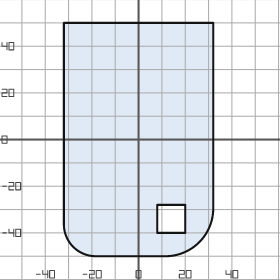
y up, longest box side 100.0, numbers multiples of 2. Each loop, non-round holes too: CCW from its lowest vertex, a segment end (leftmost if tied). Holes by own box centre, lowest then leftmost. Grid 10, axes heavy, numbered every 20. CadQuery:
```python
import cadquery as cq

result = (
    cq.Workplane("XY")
    .moveTo(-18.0, -50.0)
    .lineTo(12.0, -50.0)
    .threePointArc((26.0, -44.0), (32.0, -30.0))
    .lineTo(32.0, 50.0)
    .lineTo(-32.0, 50.0)
    .lineTo(-32.0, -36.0)
    .threePointArc((-28.0, -46.0), (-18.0, -50.0))
    .close()
    .moveTo(8.0, -40.0)
    .lineTo(20.0, -40.0)
    .lineTo(20.0, -28.0)
    .lineTo(8.0, -28.0)
    .close()
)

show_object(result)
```